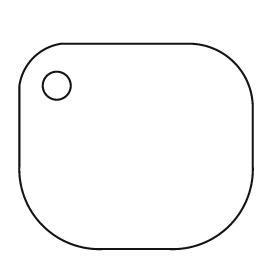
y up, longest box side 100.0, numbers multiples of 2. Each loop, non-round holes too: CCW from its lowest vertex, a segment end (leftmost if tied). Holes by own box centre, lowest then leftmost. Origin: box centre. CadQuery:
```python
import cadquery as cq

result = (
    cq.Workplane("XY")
    .moveTo(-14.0, -44.0)
    .lineTo(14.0, -44.0)
    .threePointArc((40.0, -34.0), (50.0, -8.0))
    .lineTo(50.0, 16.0)
    .threePointArc((42.0, 36.0), (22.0, 44.0))
    .lineTo(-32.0, 44.0)
    .threePointArc((-44.0, 38.0), (-50.0, 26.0))
    .lineTo(-50.0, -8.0)
    .threePointArc((-40.0, -34.0), (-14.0, -44.0))
    .close()
    .moveTo(-34.0, 26.0)
    .circle(6.0)
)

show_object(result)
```